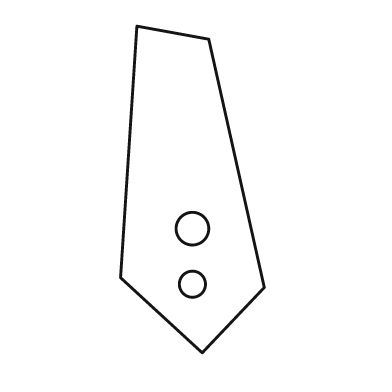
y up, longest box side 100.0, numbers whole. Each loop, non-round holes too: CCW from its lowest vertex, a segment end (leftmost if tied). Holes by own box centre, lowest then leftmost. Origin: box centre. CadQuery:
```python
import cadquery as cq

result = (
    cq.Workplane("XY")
    .moveTo(3.0, -50.0)
    .lineTo(22.0, -30.0)
    .lineTo(5.0, 46.0)
    .lineTo(-17.0, 50.0)
    .lineTo(-22.0, -27.0)
    .close()
    .moveTo(0.0, -29.0)
    .circle(4.0)
    .moveTo(0.0, -12.0)
    .circle(5.0)
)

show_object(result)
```